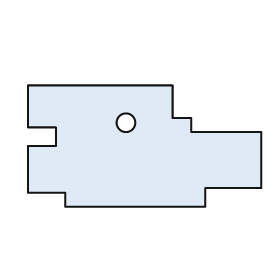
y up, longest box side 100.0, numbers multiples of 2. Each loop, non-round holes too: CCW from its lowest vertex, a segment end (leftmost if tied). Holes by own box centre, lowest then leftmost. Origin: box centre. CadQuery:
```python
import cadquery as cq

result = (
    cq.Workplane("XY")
    .moveTo(-34.0, -26.0)
    .lineTo(26.0, -26.0)
    .lineTo(26.0, -18.0)
    .lineTo(50.0, -18.0)
    .lineTo(50.0, 6.0)
    .lineTo(20.0, 6.0)
    .lineTo(20.0, 12.0)
    .lineTo(12.0, 12.0)
    .lineTo(12.0, 26.0)
    .lineTo(-50.0, 26.0)
    .lineTo(-50.0, 8.0)
    .lineTo(-38.0, 8.0)
    .lineTo(-38.0, 0.0)
    .lineTo(-50.0, 0.0)
    .lineTo(-50.0, -20.0)
    .lineTo(-34.0, -20.0)
    .close()
    .moveTo(-8.0, 10.0)
    .circle(4.0)
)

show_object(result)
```